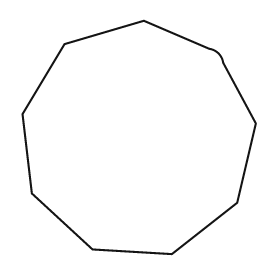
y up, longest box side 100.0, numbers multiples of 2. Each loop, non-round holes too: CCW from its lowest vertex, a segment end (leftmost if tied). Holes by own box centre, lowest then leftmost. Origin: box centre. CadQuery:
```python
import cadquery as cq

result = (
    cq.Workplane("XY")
    .moveTo(14.0, -50.0)
    .lineTo(42.0, -28.0)
    .lineTo(50.0, 6.0)
    .lineTo(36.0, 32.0)
    .threePointArc((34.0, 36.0), (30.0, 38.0))
    .lineTo(2.0, 50.0)
    .lineTo(-32.0, 40.0)
    .lineTo(-50.0, 10.0)
    .lineTo(-46.0, -24.0)
    .lineTo(-20.0, -48.0)
    .close()
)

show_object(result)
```